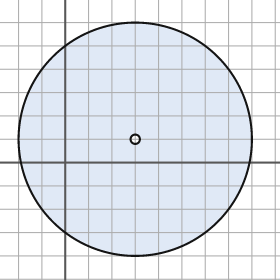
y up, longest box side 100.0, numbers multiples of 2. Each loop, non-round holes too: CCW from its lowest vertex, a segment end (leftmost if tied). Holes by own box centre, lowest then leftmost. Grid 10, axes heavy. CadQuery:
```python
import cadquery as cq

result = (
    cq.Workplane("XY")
    .moveTo(30.0, 10.0)
    .circle(50.0)
    .moveTo(30.0, 10.0)
    .circle(2.0)
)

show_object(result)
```